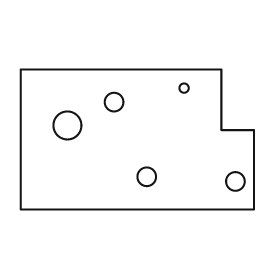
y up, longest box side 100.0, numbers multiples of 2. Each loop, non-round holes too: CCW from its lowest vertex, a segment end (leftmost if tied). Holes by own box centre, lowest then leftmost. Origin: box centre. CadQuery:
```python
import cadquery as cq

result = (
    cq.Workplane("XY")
    .moveTo(-50.0, -30.0)
    .lineTo(50.0, -30.0)
    .lineTo(50.0, 4.0)
    .lineTo(36.0, 4.0)
    .lineTo(36.0, 30.0)
    .lineTo(-50.0, 30.0)
    .close()
    .moveTo(42.0, -18.0)
    .circle(4.0)
    .moveTo(4.0, -16.0)
    .circle(4.0)
    .moveTo(-30.0, 6.0)
    .circle(6.0)
    .moveTo(-10.0, 16.0)
    .circle(4.0)
    .moveTo(20.0, 22.0)
    .circle(2.0)
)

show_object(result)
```